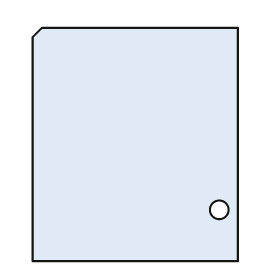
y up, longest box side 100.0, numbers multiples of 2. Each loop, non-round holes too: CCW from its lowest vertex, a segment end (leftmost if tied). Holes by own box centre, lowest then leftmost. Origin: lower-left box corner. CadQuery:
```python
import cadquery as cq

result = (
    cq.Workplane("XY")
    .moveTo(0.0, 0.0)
    .lineTo(88.0, 0.0)
    .lineTo(88.0, 100.0)
    .lineTo(4.0, 100.0)
    .lineTo(0.0, 96.0)
    .close()
    .moveTo(80.0, 22.0)
    .circle(4.0)
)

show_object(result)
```